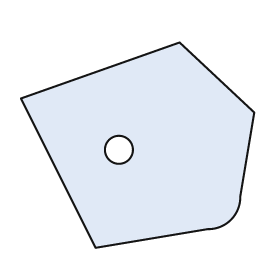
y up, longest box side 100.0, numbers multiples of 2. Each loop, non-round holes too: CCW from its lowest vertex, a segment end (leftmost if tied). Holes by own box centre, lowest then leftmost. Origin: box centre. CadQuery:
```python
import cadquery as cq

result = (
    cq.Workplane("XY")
    .moveTo(-18.0, -44.0)
    .lineTo(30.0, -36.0)
    .threePointArc((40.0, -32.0), (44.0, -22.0))
    .lineTo(50.0, 14.0)
    .lineTo(18.0, 44.0)
    .lineTo(-50.0, 20.0)
    .close()
    .moveTo(-8.0, -2.0)
    .circle(6.0)
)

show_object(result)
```